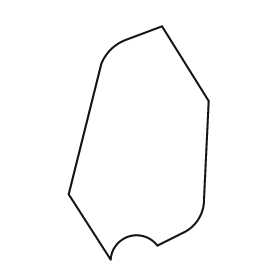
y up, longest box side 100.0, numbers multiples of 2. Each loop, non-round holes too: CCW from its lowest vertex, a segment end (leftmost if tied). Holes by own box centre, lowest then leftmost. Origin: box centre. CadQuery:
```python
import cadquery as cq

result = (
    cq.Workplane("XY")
    .moveTo(-12.0, -50.0)
    .threePointArc((-4.0, -40.0), (8.0, -44.0))
    .lineTo(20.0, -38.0)
    .threePointArc((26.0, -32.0), (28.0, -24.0))
    .lineTo(30.0, 18.0)
    .lineTo(10.0, 50.0)
    .lineTo(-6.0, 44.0)
    .threePointArc((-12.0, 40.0), (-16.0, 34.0))
    .lineTo(-30.0, -22.0)
    .close()
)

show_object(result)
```